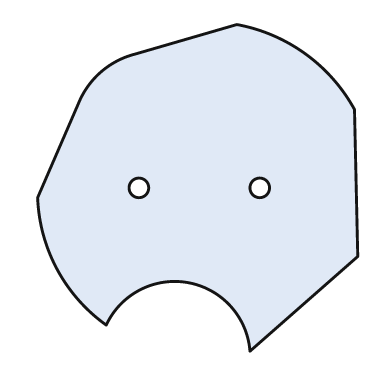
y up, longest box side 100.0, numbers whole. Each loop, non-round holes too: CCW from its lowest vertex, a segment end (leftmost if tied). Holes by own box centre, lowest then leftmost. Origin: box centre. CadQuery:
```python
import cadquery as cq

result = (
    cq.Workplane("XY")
    .moveTo(16.0, -50.0)
    .lineTo(49.0, -21.0)
    .lineTo(48.0, 24.0)
    .threePointArc((33.0, 41.0), (12.0, 50.0))
    .lineTo(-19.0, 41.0)
    .threePointArc((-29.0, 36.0), (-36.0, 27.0))
    .lineTo(-49.0, -3.0)
    .threePointArc((-43.0, -25.0), (-28.0, -42.0))
    .threePointArc((-3.0, -29.0), (16.0, -50.0))
    .close()
    .moveTo(-18.0, 0.0)
    .circle(3.0)
    .moveTo(19.0, 0.0)
    .circle(3.0)
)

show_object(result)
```